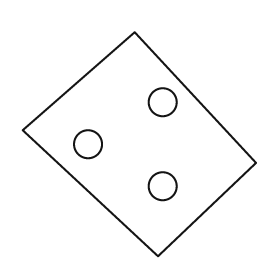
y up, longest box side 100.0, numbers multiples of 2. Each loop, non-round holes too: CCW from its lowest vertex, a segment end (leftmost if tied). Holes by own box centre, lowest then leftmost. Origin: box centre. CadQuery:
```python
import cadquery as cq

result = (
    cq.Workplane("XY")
    .moveTo(8.0, -48.0)
    .lineTo(50.0, -8.0)
    .lineTo(-2.0, 48.0)
    .lineTo(-50.0, 6.0)
    .close()
    .moveTo(10.0, -18.0)
    .circle(6.0)
    .moveTo(-22.0, 0.0)
    .circle(6.0)
    .moveTo(10.0, 18.0)
    .circle(6.0)
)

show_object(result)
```